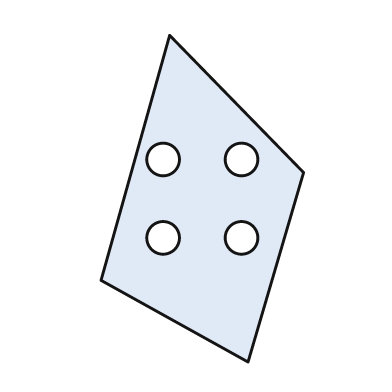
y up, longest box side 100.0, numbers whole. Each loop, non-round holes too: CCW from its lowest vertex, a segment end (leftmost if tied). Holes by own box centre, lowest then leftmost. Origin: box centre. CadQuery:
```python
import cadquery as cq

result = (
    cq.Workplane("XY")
    .moveTo(14.0, -50.0)
    .lineTo(31.0, 8.0)
    .lineTo(-10.0, 50.0)
    .lineTo(-31.0, -25.0)
    .close()
    .moveTo(-12.0, -12.0)
    .circle(5.0)
    .moveTo(12.0, -12.0)
    .circle(5.0)
    .moveTo(-12.0, 12.0)
    .circle(5.0)
    .moveTo(12.0, 12.0)
    .circle(5.0)
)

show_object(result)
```